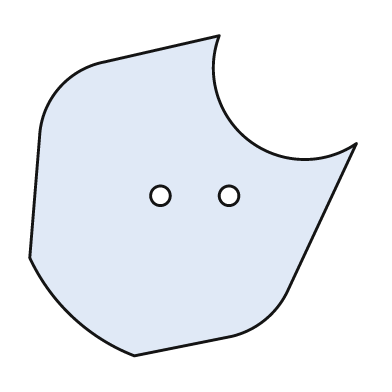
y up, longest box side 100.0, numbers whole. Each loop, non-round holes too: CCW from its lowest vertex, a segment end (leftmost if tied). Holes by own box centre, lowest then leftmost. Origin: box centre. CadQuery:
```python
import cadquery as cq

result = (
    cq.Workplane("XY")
    .moveTo(-18.0, -49.0)
    .lineTo(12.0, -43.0)
    .threePointArc((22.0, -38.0), (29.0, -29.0))
    .lineTo(50.0, 16.0)
    .threePointArc((17.0, 17.0), (8.0, 49.0))
    .lineTo(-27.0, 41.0)
    .threePointArc((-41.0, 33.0), (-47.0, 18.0))
    .lineTo(-50.0, -19.0)
    .threePointArc((-37.0, -37.0), (-18.0, -49.0))
    .close()
    .moveTo(-10.0, 0.0)
    .circle(3.0)
    .moveTo(11.0, 0.0)
    .circle(3.0)
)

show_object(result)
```